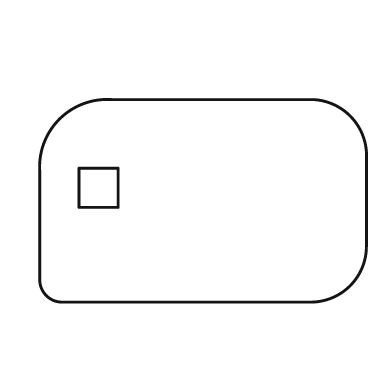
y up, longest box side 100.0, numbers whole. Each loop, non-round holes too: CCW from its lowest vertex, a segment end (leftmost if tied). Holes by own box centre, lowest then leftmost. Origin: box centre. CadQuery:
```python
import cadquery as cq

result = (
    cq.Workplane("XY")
    .moveTo(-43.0, -31.0)
    .lineTo(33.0, -31.0)
    .threePointArc((45.0, -26.0), (50.0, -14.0))
    .lineTo(50.0, 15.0)
    .threePointArc((45.0, 26.0), (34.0, 31.0))
    .lineTo(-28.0, 31.0)
    .threePointArc((-44.0, 25.0), (-50.0, 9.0))
    .lineTo(-50.0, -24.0)
    .threePointArc((-48.0, -29.0), (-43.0, -31.0))
    .close()
    .moveTo(-38.0, -2.0)
    .lineTo(-26.0, -2.0)
    .lineTo(-26.0, 10.0)
    .lineTo(-38.0, 10.0)
    .close()
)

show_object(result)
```